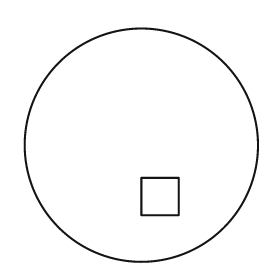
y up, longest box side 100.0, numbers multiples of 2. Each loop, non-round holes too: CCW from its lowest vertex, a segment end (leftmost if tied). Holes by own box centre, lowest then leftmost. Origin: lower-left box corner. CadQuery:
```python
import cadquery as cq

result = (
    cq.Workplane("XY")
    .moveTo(50.0, 50.0)
    .circle(50.0)
    .moveTo(50.0, 20.0)
    .lineTo(66.0, 20.0)
    .lineTo(66.0, 36.0)
    .lineTo(50.0, 36.0)
    .close()
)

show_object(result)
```